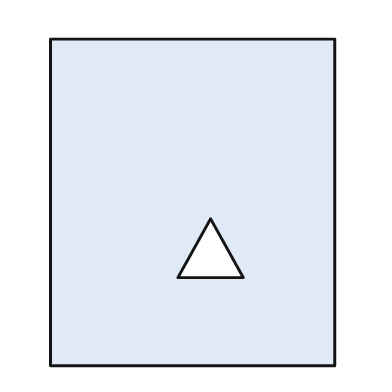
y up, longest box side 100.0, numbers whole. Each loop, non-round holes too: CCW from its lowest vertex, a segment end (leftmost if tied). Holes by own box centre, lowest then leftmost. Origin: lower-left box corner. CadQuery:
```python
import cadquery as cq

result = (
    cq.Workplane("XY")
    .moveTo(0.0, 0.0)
    .lineTo(87.0, 0.0)
    .lineTo(87.0, 100.0)
    .lineTo(0.0, 100.0)
    .close()
    .moveTo(39.0, 27.0)
    .lineTo(59.0, 27.0)
    .lineTo(49.0, 45.0)
    .close()
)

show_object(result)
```